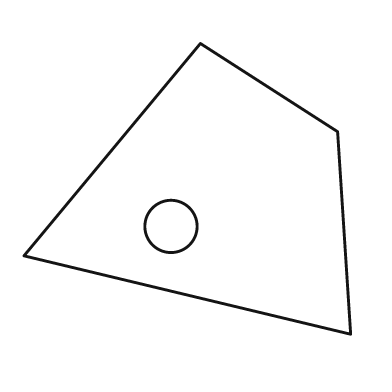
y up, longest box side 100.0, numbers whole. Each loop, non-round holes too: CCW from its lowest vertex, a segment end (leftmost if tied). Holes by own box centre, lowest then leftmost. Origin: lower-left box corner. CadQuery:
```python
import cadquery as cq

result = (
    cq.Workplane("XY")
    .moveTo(100.0, 0.0)
    .lineTo(96.0, 62.0)
    .lineTo(54.0, 89.0)
    .lineTo(0.0, 24.0)
    .close()
    .moveTo(45.0, 33.0)
    .circle(8.0)
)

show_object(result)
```